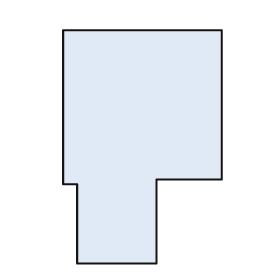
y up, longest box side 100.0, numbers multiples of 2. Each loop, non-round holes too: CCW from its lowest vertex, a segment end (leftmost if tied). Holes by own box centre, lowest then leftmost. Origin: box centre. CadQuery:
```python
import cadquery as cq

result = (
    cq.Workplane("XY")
    .moveTo(-28.0, -50.0)
    .lineTo(6.0, -50.0)
    .lineTo(6.0, -14.0)
    .lineTo(34.0, -14.0)
    .lineTo(34.0, 50.0)
    .lineTo(-34.0, 50.0)
    .lineTo(-34.0, -16.0)
    .lineTo(-28.0, -16.0)
    .close()
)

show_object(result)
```